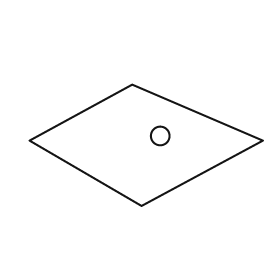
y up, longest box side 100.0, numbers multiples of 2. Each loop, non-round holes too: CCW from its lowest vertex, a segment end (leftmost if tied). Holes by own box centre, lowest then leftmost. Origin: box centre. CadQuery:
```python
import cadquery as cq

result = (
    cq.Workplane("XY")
    .moveTo(-2.0, -26.0)
    .lineTo(50.0, 2.0)
    .lineTo(-6.0, 26.0)
    .lineTo(-50.0, 2.0)
    .close()
    .moveTo(6.0, 4.0)
    .circle(4.0)
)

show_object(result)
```